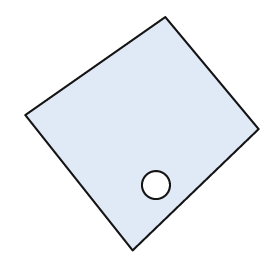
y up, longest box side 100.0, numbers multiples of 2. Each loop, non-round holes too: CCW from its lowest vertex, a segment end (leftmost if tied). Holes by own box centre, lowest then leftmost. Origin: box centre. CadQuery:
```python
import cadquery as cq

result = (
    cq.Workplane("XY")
    .moveTo(-4.0, -50.0)
    .lineTo(50.0, 2.0)
    .lineTo(10.0, 50.0)
    .lineTo(-50.0, 8.0)
    .close()
    .moveTo(6.0, -22.0)
    .circle(6.0)
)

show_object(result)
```